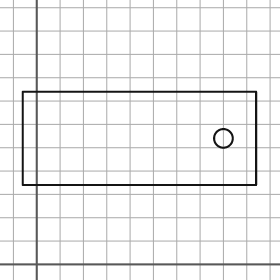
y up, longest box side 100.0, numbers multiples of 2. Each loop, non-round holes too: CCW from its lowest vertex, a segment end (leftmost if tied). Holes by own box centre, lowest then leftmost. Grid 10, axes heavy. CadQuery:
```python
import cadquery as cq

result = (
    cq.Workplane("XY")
    .moveTo(-6.0, 34.0)
    .lineTo(94.0, 34.0)
    .lineTo(94.0, 74.0)
    .lineTo(-6.0, 74.0)
    .close()
    .moveTo(80.0, 54.0)
    .circle(4.0)
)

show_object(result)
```